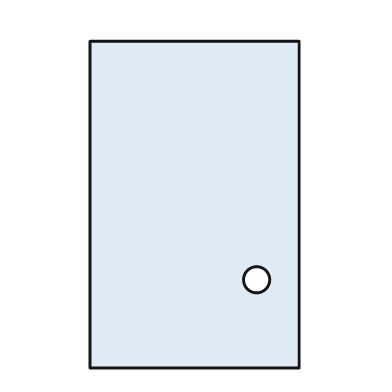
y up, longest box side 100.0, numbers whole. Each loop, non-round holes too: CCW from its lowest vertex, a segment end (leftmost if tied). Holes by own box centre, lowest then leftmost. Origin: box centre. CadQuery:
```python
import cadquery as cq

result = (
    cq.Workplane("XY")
    .moveTo(-32.0, -50.0)
    .lineTo(32.0, -50.0)
    .lineTo(32.0, 50.0)
    .lineTo(-32.0, 50.0)
    .close()
    .moveTo(19.0, -23.0)
    .circle(4.0)
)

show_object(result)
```